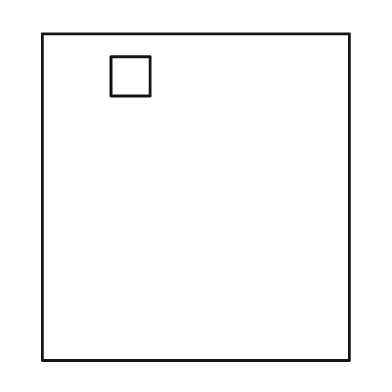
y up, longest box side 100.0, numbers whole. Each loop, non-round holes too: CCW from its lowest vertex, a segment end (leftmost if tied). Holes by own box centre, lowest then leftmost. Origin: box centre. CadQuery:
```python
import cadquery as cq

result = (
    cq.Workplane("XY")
    .moveTo(-47.0, -50.0)
    .lineTo(47.0, -50.0)
    .lineTo(47.0, 50.0)
    .lineTo(-47.0, 50.0)
    .close()
    .moveTo(-26.0, 31.0)
    .lineTo(-14.0, 31.0)
    .lineTo(-14.0, 43.0)
    .lineTo(-26.0, 43.0)
    .close()
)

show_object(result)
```